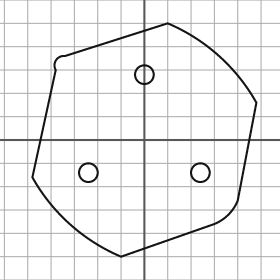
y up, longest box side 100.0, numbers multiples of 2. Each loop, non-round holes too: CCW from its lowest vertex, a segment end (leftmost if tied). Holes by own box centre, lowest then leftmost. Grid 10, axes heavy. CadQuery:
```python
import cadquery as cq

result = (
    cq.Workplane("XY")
    .moveTo(-10.0, -50.0)
    .lineTo(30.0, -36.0)
    .threePointArc((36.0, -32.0), (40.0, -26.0))
    .lineTo(48.0, 16.0)
    .threePointArc((32.0, 36.0), (10.0, 50.0))
    .lineTo(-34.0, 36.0)
    .threePointArc((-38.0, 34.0), (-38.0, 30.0))
    .lineTo(-48.0, -16.0)
    .threePointArc((-32.0, -36.0), (-10.0, -50.0))
    .close()
    .moveTo(-24.0, -14.0)
    .circle(4.0)
    .moveTo(24.0, -14.0)
    .circle(4.0)
    .moveTo(0.0, 28.0)
    .circle(4.0)
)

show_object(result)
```